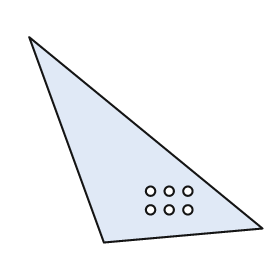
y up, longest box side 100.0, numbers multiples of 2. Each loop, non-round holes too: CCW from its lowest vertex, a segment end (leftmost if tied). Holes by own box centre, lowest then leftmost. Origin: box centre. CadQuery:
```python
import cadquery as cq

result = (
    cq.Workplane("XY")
    .moveTo(-18.0, -44.0)
    .lineTo(50.0, -38.0)
    .lineTo(-50.0, 44.0)
    .close()
    .moveTo(2.0, -30.0)
    .circle(2.0)
    .moveTo(10.0, -30.0)
    .circle(2.0)
    .moveTo(18.0, -30.0)
    .circle(2.0)
    .moveTo(2.0, -22.0)
    .circle(2.0)
    .moveTo(10.0, -22.0)
    .circle(2.0)
    .moveTo(18.0, -22.0)
    .circle(2.0)
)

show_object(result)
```